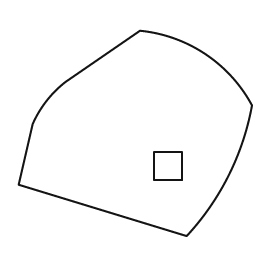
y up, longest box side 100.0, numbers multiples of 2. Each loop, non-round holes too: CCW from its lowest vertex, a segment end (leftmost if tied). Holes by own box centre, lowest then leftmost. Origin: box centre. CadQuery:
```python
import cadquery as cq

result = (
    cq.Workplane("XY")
    .moveTo(22.0, -44.0)
    .threePointArc((40.0, -18.0), (50.0, 12.0))
    .threePointArc((30.0, 34.0), (2.0, 44.0))
    .lineTo(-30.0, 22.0)
    .threePointArc((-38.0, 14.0), (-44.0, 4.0))
    .lineTo(-50.0, -22.0)
    .close()
    .moveTo(8.0, -20.0)
    .lineTo(20.0, -20.0)
    .lineTo(20.0, -8.0)
    .lineTo(8.0, -8.0)
    .close()
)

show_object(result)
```